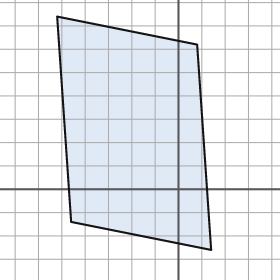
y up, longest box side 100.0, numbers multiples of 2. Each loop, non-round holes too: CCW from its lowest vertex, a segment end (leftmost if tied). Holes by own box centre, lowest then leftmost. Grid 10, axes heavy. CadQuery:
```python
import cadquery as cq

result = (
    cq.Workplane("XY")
    .moveTo(14.0, -26.0)
    .lineTo(8.0, 62.0)
    .lineTo(-52.0, 74.0)
    .lineTo(-46.0, -14.0)
    .close()
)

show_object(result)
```